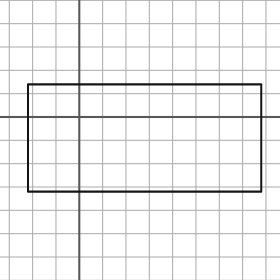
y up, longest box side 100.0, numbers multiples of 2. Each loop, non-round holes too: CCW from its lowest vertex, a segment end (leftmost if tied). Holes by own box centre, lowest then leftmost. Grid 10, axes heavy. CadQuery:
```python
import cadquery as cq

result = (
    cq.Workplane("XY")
    .moveTo(-22.0, -32.0)
    .lineTo(78.0, -32.0)
    .lineTo(78.0, 14.0)
    .lineTo(-22.0, 14.0)
    .close()
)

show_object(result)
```